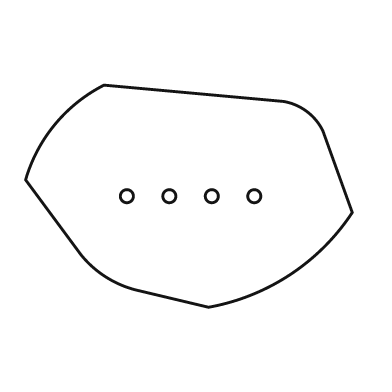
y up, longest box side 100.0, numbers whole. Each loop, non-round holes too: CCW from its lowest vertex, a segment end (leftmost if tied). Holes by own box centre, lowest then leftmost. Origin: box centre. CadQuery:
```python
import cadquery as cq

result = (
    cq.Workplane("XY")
    .moveTo(6.0, -34.0)
    .threePointArc((31.0, -24.0), (50.0, -5.0))
    .lineTo(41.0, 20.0)
    .threePointArc((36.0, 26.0), (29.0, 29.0))
    .lineTo(-26.0, 34.0)
    .threePointArc((-41.0, 22.0), (-50.0, 5.0))
    .lineTo(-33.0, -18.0)
    .threePointArc((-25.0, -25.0), (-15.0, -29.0))
    .close()
    .moveTo(-19.0, 0.0)
    .circle(2.0)
    .moveTo(-6.0, 0.0)
    .circle(2.0)
    .moveTo(7.0, 0.0)
    .circle(2.0)
    .moveTo(20.0, 0.0)
    .circle(2.0)
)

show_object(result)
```